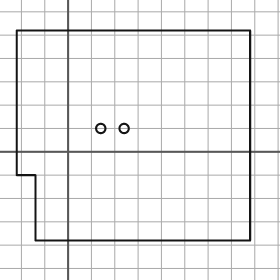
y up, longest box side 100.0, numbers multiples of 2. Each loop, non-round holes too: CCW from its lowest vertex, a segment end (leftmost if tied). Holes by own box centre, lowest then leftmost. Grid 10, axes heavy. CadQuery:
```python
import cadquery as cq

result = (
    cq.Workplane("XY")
    .moveTo(-14.0, -38.0)
    .lineTo(78.0, -38.0)
    .lineTo(78.0, 52.0)
    .lineTo(-22.0, 52.0)
    .lineTo(-22.0, -10.0)
    .lineTo(-14.0, -10.0)
    .close()
    .moveTo(14.0, 10.0)
    .circle(2.0)
    .moveTo(24.0, 10.0)
    .circle(2.0)
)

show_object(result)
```